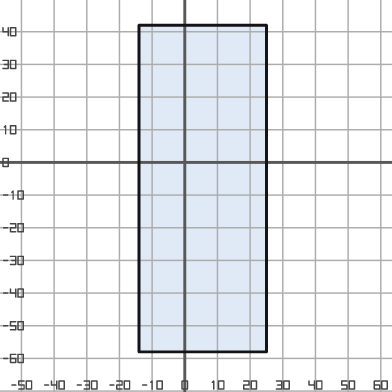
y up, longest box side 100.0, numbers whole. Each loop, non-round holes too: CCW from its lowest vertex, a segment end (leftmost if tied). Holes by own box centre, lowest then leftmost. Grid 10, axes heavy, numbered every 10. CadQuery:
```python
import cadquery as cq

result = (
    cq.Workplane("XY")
    .moveTo(-14.0, -58.0)
    .lineTo(25.0, -58.0)
    .lineTo(25.0, 42.0)
    .lineTo(-14.0, 42.0)
    .close()
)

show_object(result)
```